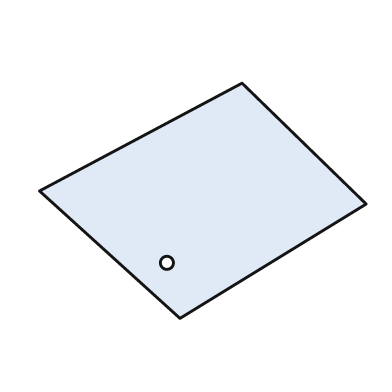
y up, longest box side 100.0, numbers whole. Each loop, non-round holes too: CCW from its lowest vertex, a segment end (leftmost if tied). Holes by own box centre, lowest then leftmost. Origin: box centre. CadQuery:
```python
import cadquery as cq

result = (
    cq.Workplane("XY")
    .moveTo(-7.0, -36.0)
    .lineTo(50.0, -1.0)
    .lineTo(12.0, 36.0)
    .lineTo(-50.0, 3.0)
    .close()
    .moveTo(-11.0, -19.0)
    .circle(2.0)
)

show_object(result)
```